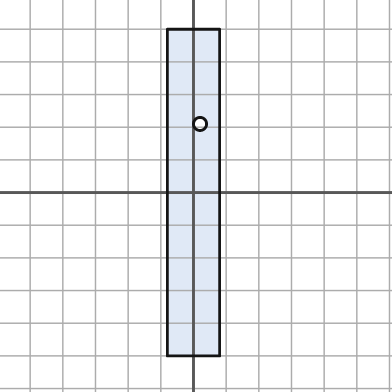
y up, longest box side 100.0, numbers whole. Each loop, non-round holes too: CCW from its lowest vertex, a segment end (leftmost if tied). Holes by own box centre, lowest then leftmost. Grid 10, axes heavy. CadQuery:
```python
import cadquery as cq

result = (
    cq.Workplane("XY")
    .moveTo(-8.0, -50.0)
    .lineTo(8.0, -50.0)
    .lineTo(8.0, 50.0)
    .lineTo(-8.0, 50.0)
    .close()
    .moveTo(2.0, 21.0)
    .circle(2.0)
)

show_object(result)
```